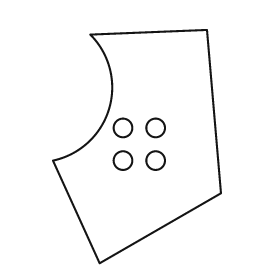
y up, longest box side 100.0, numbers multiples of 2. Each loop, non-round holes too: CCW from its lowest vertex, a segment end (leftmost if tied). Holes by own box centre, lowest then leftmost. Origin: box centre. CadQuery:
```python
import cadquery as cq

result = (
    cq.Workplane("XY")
    .moveTo(-16.0, -50.0)
    .lineTo(36.0, -20.0)
    .lineTo(30.0, 50.0)
    .lineTo(-20.0, 48.0)
    .threePointArc((-12.0, 16.0), (-36.0, -6.0))
    .close()
    .moveTo(-6.0, -6.0)
    .circle(4.0)
    .moveTo(8.0, -6.0)
    .circle(4.0)
    .moveTo(-6.0, 8.0)
    .circle(4.0)
    .moveTo(8.0, 8.0)
    .circle(4.0)
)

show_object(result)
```